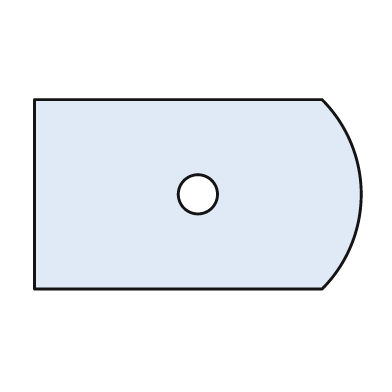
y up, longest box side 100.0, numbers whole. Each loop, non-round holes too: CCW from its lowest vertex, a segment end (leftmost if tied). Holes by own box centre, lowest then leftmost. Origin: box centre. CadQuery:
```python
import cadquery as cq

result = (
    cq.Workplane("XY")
    .moveTo(-50.0, -29.0)
    .lineTo(38.0, -29.0)
    .threePointArc((50.0, 0.0), (38.0, 29.0))
    .lineTo(-50.0, 29.0)
    .close()
    .moveTo(0.0, 0.0)
    .circle(6.0)
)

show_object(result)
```